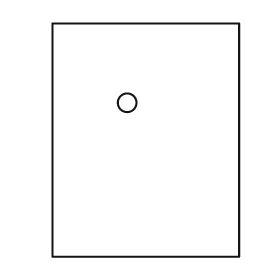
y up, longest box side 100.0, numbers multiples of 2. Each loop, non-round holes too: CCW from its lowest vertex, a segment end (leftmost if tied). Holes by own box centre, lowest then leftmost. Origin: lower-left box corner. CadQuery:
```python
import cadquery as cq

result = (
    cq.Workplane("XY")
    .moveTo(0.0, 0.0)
    .lineTo(80.0, 0.0)
    .lineTo(80.0, 100.0)
    .lineTo(0.0, 100.0)
    .close()
    .moveTo(32.0, 66.0)
    .circle(4.0)
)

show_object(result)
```